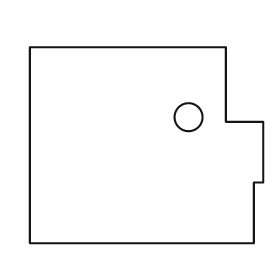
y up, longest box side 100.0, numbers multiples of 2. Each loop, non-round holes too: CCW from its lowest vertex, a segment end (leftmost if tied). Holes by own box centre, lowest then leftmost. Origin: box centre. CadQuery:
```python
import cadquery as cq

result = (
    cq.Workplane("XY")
    .moveTo(-50.0, -42.0)
    .lineTo(46.0, -42.0)
    .lineTo(46.0, -16.0)
    .lineTo(50.0, -16.0)
    .lineTo(50.0, 10.0)
    .lineTo(34.0, 10.0)
    .lineTo(34.0, 42.0)
    .lineTo(-50.0, 42.0)
    .close()
    .moveTo(18.0, 12.0)
    .circle(6.0)
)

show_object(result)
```